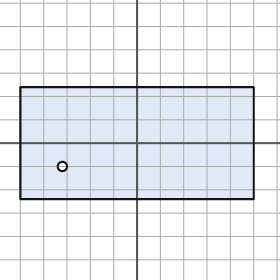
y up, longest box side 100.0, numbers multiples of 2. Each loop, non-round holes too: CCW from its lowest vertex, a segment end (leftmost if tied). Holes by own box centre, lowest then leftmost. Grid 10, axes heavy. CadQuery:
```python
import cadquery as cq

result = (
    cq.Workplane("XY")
    .moveTo(-50.0, -24.0)
    .lineTo(50.0, -24.0)
    .lineTo(50.0, 24.0)
    .lineTo(-50.0, 24.0)
    .close()
    .moveTo(-32.0, -10.0)
    .circle(2.0)
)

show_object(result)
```